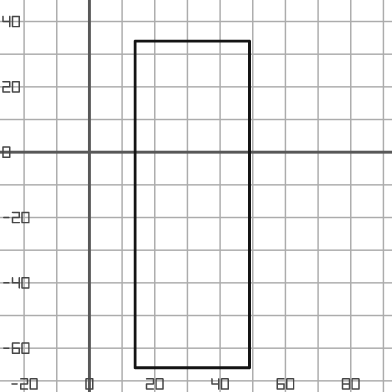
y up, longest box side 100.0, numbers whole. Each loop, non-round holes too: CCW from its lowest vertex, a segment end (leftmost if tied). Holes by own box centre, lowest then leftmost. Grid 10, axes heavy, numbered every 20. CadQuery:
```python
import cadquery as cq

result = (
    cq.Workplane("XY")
    .moveTo(14.0, -66.0)
    .lineTo(49.0, -66.0)
    .lineTo(49.0, 34.0)
    .lineTo(14.0, 34.0)
    .close()
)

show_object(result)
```